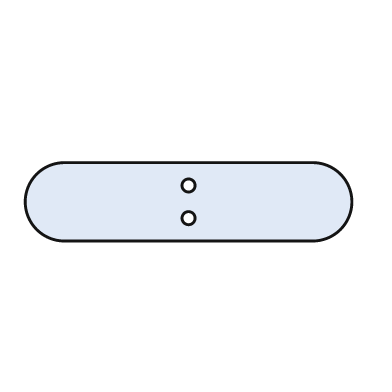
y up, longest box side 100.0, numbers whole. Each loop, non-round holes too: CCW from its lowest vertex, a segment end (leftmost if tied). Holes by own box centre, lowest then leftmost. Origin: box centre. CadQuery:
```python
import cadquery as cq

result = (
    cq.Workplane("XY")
    .moveTo(-38.0, -12.0)
    .lineTo(38.0, -12.0)
    .threePointArc((50.0, 0.0), (38.0, 12.0))
    .lineTo(-38.0, 12.0)
    .threePointArc((-50.0, 0.0), (-38.0, -12.0))
    .close()
    .moveTo(0.0, -5.0)
    .circle(2.0)
    .moveTo(0.0, 5.0)
    .circle(2.0)
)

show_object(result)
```